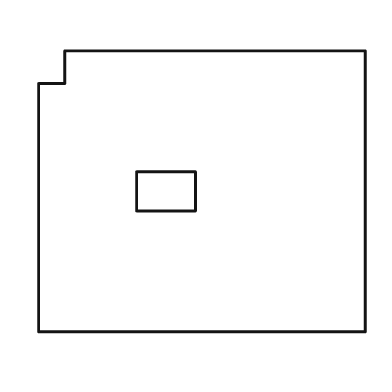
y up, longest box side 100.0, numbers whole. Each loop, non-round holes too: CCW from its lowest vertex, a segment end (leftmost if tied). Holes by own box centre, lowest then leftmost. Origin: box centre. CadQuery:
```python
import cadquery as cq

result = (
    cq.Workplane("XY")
    .moveTo(-50.0, -43.0)
    .lineTo(50.0, -43.0)
    .lineTo(50.0, 43.0)
    .lineTo(-42.0, 43.0)
    .lineTo(-42.0, 33.0)
    .lineTo(-50.0, 33.0)
    .close()
    .moveTo(-20.0, -6.0)
    .lineTo(-2.0, -6.0)
    .lineTo(-2.0, 6.0)
    .lineTo(-20.0, 6.0)
    .close()
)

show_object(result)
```